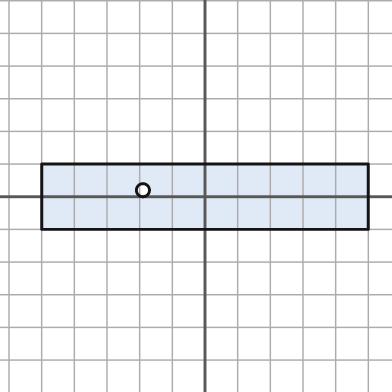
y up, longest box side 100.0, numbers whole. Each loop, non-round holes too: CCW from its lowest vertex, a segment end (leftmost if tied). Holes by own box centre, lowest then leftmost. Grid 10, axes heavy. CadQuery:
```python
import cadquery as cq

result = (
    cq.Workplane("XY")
    .moveTo(-50.0, -10.0)
    .lineTo(50.0, -10.0)
    .lineTo(50.0, 10.0)
    .lineTo(-50.0, 10.0)
    .close()
    .moveTo(-19.0, 2.0)
    .circle(2.0)
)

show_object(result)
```